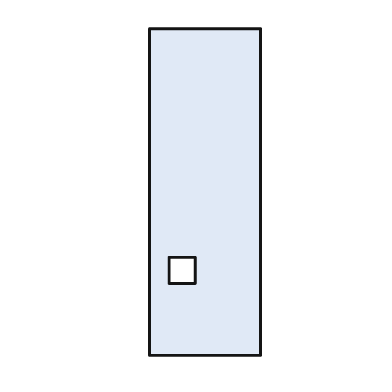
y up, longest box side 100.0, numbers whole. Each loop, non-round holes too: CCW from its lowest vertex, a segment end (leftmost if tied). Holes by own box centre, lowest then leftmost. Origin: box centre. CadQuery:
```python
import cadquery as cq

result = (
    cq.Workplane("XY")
    .moveTo(-17.0, -50.0)
    .lineTo(17.0, -50.0)
    .lineTo(17.0, 50.0)
    .lineTo(-17.0, 50.0)
    .close()
    .moveTo(-11.0, -28.0)
    .lineTo(-3.0, -28.0)
    .lineTo(-3.0, -20.0)
    .lineTo(-11.0, -20.0)
    .close()
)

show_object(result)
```